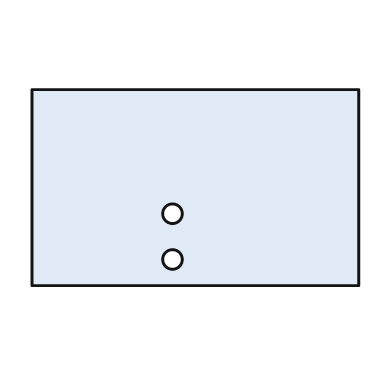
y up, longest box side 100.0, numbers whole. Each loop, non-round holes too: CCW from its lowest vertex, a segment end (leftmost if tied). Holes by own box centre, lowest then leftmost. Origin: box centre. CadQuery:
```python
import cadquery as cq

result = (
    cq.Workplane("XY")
    .moveTo(-50.0, -30.0)
    .lineTo(50.0, -30.0)
    .lineTo(50.0, 30.0)
    .lineTo(-50.0, 30.0)
    .close()
    .moveTo(-7.0, -22.0)
    .circle(3.0)
    .moveTo(-7.0, -8.0)
    .circle(3.0)
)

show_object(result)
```